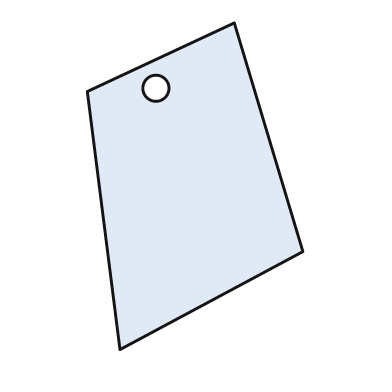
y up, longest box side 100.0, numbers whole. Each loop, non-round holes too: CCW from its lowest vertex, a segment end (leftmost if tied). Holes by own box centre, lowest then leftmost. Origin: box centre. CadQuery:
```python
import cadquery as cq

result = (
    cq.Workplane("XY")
    .moveTo(-23.0, -50.0)
    .lineTo(33.0, -20.0)
    .lineTo(12.0, 50.0)
    .lineTo(-33.0, 29.0)
    .close()
    .moveTo(-12.0, 30.0)
    .circle(4.0)
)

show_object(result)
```